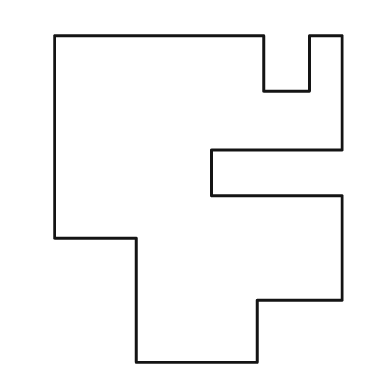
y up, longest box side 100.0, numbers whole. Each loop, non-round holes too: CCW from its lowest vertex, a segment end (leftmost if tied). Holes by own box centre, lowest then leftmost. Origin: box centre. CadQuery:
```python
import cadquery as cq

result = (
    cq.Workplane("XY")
    .moveTo(-19.0, -50.0)
    .lineTo(18.0, -50.0)
    .lineTo(18.0, -31.0)
    .lineTo(44.0, -31.0)
    .lineTo(44.0, 1.0)
    .lineTo(4.0, 1.0)
    .lineTo(4.0, 15.0)
    .lineTo(44.0, 15.0)
    .lineTo(44.0, 50.0)
    .lineTo(34.0, 50.0)
    .lineTo(34.0, 33.0)
    .lineTo(20.0, 33.0)
    .lineTo(20.0, 50.0)
    .lineTo(-44.0, 50.0)
    .lineTo(-44.0, -12.0)
    .lineTo(-19.0, -12.0)
    .close()
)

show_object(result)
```